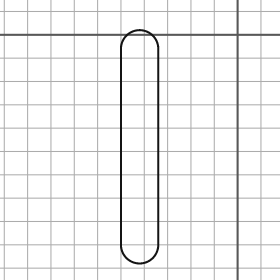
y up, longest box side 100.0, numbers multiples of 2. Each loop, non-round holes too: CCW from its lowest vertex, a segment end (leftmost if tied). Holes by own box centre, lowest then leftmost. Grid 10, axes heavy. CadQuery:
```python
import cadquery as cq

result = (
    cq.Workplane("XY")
    .moveTo(-50.0, -90.0)
    .threePointArc((-42.0, -98.0), (-34.0, -90.0))
    .lineTo(-34.0, -6.0)
    .threePointArc((-42.0, 2.0), (-50.0, -6.0))
    .close()
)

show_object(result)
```